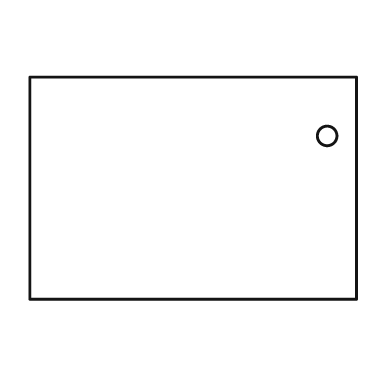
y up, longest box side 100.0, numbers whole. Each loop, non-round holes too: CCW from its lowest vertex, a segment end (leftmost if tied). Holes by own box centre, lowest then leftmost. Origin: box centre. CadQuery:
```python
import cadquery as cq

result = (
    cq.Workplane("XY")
    .moveTo(-50.0, -34.0)
    .lineTo(50.0, -34.0)
    .lineTo(50.0, 34.0)
    .lineTo(-50.0, 34.0)
    .close()
    .moveTo(41.0, 16.0)
    .circle(3.0)
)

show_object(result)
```